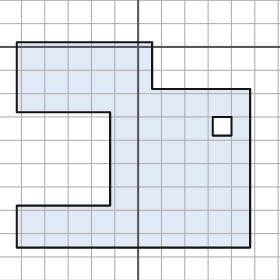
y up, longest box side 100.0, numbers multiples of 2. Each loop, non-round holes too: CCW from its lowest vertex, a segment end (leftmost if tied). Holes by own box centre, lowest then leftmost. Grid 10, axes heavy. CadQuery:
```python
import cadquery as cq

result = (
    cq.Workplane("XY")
    .moveTo(-52.0, -86.0)
    .lineTo(48.0, -86.0)
    .lineTo(48.0, -18.0)
    .lineTo(6.0, -18.0)
    .lineTo(6.0, 2.0)
    .lineTo(-52.0, 2.0)
    .lineTo(-52.0, -28.0)
    .lineTo(-12.0, -28.0)
    .lineTo(-12.0, -68.0)
    .lineTo(-52.0, -68.0)
    .close()
    .moveTo(32.0, -38.0)
    .lineTo(40.0, -38.0)
    .lineTo(40.0, -30.0)
    .lineTo(32.0, -30.0)
    .close()
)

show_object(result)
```